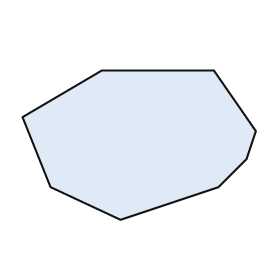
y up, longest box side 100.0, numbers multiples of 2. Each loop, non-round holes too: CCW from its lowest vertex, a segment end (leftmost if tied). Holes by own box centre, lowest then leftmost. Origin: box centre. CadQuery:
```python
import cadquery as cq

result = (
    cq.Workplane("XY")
    .moveTo(-8.0, -32.0)
    .lineTo(34.0, -18.0)
    .lineTo(46.0, -6.0)
    .lineTo(50.0, 6.0)
    .lineTo(32.0, 32.0)
    .lineTo(-16.0, 32.0)
    .lineTo(-50.0, 12.0)
    .lineTo(-38.0, -18.0)
    .close()
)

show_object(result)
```